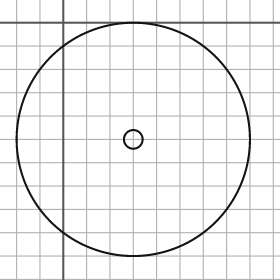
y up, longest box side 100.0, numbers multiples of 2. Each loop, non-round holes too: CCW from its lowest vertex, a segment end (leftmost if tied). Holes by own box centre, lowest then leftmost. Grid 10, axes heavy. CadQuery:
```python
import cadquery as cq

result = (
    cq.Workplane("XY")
    .moveTo(30.0, -50.0)
    .circle(50.0)
    .moveTo(30.0, -50.0)
    .circle(4.0)
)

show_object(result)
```